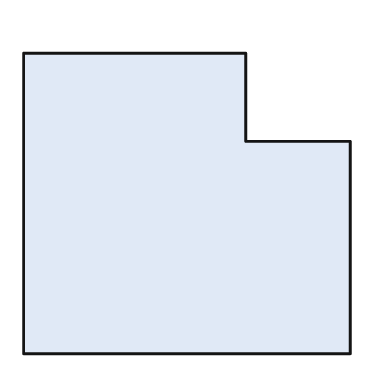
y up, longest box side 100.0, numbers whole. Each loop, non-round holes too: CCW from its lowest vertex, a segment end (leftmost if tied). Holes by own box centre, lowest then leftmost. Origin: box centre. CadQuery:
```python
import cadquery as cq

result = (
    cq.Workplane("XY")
    .moveTo(-50.0, -46.0)
    .lineTo(50.0, -46.0)
    .lineTo(50.0, 19.0)
    .lineTo(18.0, 19.0)
    .lineTo(18.0, 46.0)
    .lineTo(-50.0, 46.0)
    .close()
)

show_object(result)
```